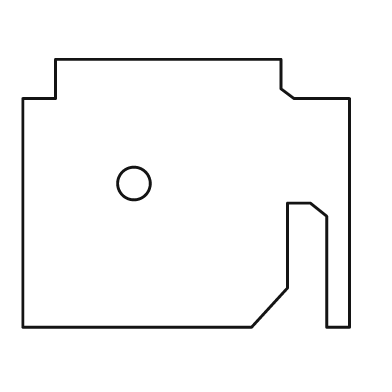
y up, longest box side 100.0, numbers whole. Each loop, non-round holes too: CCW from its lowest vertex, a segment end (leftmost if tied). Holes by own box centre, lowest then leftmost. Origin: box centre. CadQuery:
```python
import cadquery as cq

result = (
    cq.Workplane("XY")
    .moveTo(-50.0, -41.0)
    .lineTo(20.0, -41.0)
    .lineTo(31.0, -29.0)
    .lineTo(31.0, -3.0)
    .lineTo(38.0, -3.0)
    .lineTo(43.0, -7.0)
    .lineTo(43.0, -41.0)
    .lineTo(50.0, -41.0)
    .lineTo(50.0, 29.0)
    .lineTo(33.0, 29.0)
    .lineTo(29.0, 32.0)
    .lineTo(29.0, 41.0)
    .lineTo(-40.0, 41.0)
    .lineTo(-40.0, 29.0)
    .lineTo(-50.0, 29.0)
    .close()
    .moveTo(-16.0, 3.0)
    .circle(5.0)
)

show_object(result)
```